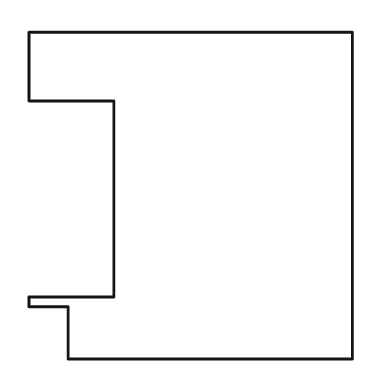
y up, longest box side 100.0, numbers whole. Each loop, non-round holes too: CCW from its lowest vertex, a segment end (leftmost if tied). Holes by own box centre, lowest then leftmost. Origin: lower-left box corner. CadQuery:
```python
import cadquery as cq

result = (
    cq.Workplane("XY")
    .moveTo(12.0, 0.0)
    .lineTo(99.0, 0.0)
    .lineTo(99.0, 100.0)
    .lineTo(0.0, 100.0)
    .lineTo(0.0, 79.0)
    .lineTo(26.0, 79.0)
    .lineTo(26.0, 19.0)
    .lineTo(0.0, 19.0)
    .lineTo(0.0, 16.0)
    .lineTo(12.0, 16.0)
    .close()
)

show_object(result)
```